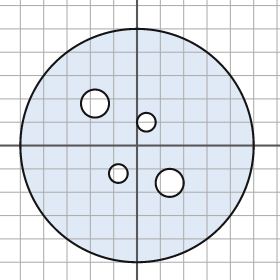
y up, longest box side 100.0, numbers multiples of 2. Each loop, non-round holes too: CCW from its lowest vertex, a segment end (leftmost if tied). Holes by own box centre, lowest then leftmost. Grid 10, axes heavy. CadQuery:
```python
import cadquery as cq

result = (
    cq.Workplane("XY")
    .moveTo(0.0, 0.0)
    .circle(50.0)
    .moveTo(14.0, -16.0)
    .circle(6.0)
    .moveTo(-8.0, -12.0)
    .circle(4.0)
    .moveTo(4.0, 10.0)
    .circle(4.0)
    .moveTo(-18.0, 18.0)
    .circle(6.0)
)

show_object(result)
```